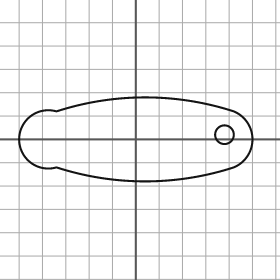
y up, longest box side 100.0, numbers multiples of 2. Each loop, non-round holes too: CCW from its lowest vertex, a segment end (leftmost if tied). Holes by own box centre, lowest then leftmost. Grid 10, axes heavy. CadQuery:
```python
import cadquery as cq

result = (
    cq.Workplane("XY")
    .moveTo(-34.0, -12.0)
    .threePointArc((4.0, -18.0), (42.0, -12.0))
    .threePointArc((50.0, 0.0), (42.0, 12.0))
    .threePointArc((4.0, 18.0), (-34.0, 12.0))
    .threePointArc((-50.0, 0.0), (-34.0, -12.0))
    .close()
    .moveTo(38.0, 2.0)
    .circle(4.0)
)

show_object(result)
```